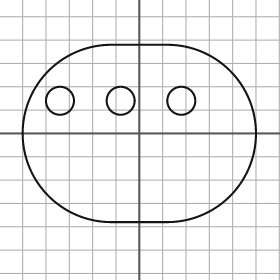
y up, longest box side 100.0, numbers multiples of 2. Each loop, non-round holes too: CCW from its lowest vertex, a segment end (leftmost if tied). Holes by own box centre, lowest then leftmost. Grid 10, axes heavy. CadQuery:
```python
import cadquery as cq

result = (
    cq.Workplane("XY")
    .moveTo(-12.0, -38.0)
    .lineTo(12.0, -38.0)
    .threePointArc((50.0, 0.0), (12.0, 38.0))
    .lineTo(-12.0, 38.0)
    .threePointArc((-50.0, 0.0), (-12.0, -38.0))
    .close()
    .moveTo(-34.0, 14.0)
    .circle(6.0)
    .moveTo(-8.0, 14.0)
    .circle(6.0)
    .moveTo(18.0, 14.0)
    .circle(6.0)
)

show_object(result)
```